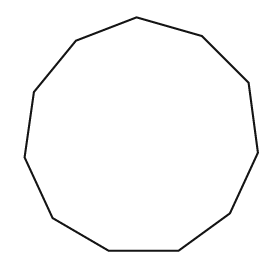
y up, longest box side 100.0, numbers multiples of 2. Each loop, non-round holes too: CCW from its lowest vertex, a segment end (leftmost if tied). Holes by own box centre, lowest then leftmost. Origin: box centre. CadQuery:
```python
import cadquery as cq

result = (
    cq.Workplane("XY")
    .moveTo(-14.0, -50.0)
    .lineTo(16.0, -50.0)
    .lineTo(38.0, -34.0)
    .lineTo(50.0, -8.0)
    .lineTo(46.0, 22.0)
    .lineTo(26.0, 42.0)
    .lineTo(-2.0, 50.0)
    .lineTo(-28.0, 40.0)
    .lineTo(-46.0, 18.0)
    .lineTo(-50.0, -10.0)
    .lineTo(-38.0, -36.0)
    .close()
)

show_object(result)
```